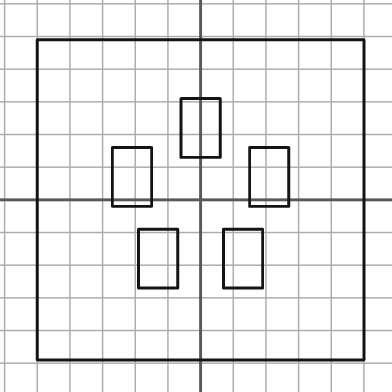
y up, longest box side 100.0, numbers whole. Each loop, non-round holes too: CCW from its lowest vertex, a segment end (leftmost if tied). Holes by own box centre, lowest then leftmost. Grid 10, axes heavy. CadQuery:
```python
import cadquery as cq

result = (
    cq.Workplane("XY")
    .moveTo(-50.0, -49.0)
    .lineTo(50.0, -49.0)
    .lineTo(50.0, 49.0)
    .lineTo(-50.0, 49.0)
    .close()
    .moveTo(-19.0, -27.0)
    .lineTo(-7.0, -27.0)
    .lineTo(-7.0, -9.0)
    .lineTo(-19.0, -9.0)
    .close()
    .moveTo(7.0, -27.0)
    .lineTo(19.0, -27.0)
    .lineTo(19.0, -9.0)
    .lineTo(7.0, -9.0)
    .close()
    .moveTo(-27.0, -2.0)
    .lineTo(-15.0, -2.0)
    .lineTo(-15.0, 16.0)
    .lineTo(-27.0, 16.0)
    .close()
    .moveTo(15.0, -2.0)
    .lineTo(27.0, -2.0)
    .lineTo(27.0, 16.0)
    .lineTo(15.0, 16.0)
    .close()
    .moveTo(-6.0, 13.0)
    .lineTo(6.0, 13.0)
    .lineTo(6.0, 31.0)
    .lineTo(-6.0, 31.0)
    .close()
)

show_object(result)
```